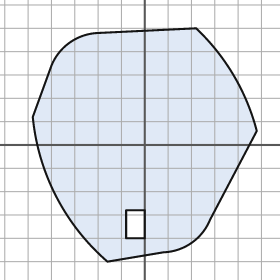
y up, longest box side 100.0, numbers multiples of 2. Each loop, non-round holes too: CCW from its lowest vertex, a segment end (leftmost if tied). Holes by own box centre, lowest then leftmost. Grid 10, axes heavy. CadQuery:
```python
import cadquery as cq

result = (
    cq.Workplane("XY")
    .moveTo(-16.0, -50.0)
    .lineTo(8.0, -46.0)
    .threePointArc((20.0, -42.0), (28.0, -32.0))
    .lineTo(48.0, 6.0)
    .threePointArc((38.0, 30.0), (22.0, 50.0))
    .lineTo(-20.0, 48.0)
    .threePointArc((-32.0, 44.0), (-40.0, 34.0))
    .lineTo(-48.0, 12.0)
    .threePointArc((-38.0, -22.0), (-16.0, -50.0))
    .close()
    .moveTo(-8.0, -40.0)
    .lineTo(0.0, -40.0)
    .lineTo(0.0, -28.0)
    .lineTo(-8.0, -28.0)
    .close()
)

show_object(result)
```